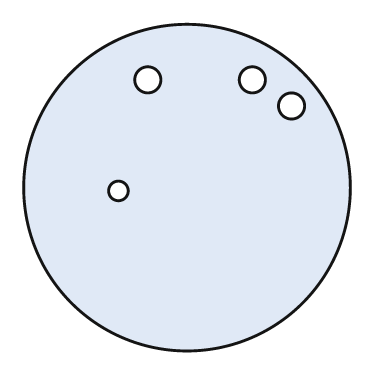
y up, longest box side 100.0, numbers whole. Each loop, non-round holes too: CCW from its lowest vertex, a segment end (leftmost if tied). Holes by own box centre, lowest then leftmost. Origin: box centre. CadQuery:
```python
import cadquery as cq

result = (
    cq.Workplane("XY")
    .moveTo(0.0, 0.0)
    .circle(50.0)
    .moveTo(-21.0, -1.0)
    .circle(3.0)
    .moveTo(32.0, 25.0)
    .circle(4.0)
    .moveTo(-12.0, 33.0)
    .circle(4.0)
    .moveTo(20.0, 33.0)
    .circle(4.0)
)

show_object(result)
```